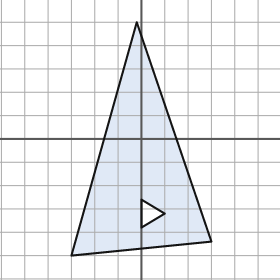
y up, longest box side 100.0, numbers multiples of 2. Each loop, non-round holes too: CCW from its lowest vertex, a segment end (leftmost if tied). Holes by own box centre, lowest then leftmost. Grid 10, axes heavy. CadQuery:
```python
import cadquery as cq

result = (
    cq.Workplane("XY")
    .moveTo(-30.0, -50.0)
    .lineTo(30.0, -44.0)
    .lineTo(-2.0, 50.0)
    .close()
    .moveTo(0.0, -38.0)
    .lineTo(10.0, -32.0)
    .lineTo(0.0, -26.0)
    .close()
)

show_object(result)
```